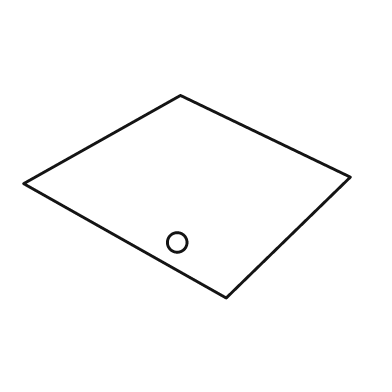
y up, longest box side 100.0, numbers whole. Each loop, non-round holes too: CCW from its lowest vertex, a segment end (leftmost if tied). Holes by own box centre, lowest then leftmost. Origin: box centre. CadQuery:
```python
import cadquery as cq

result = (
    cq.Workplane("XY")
    .moveTo(12.0, -31.0)
    .lineTo(50.0, 6.0)
    .lineTo(-2.0, 31.0)
    .lineTo(-50.0, 4.0)
    .close()
    .moveTo(-3.0, -14.0)
    .circle(3.0)
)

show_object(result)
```